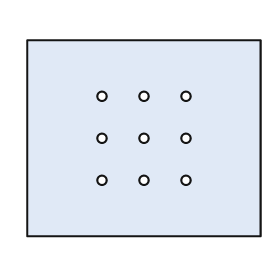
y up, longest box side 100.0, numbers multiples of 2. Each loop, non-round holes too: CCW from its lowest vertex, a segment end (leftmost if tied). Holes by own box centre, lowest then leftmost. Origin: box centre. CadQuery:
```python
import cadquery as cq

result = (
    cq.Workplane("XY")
    .moveTo(-50.0, -42.0)
    .lineTo(50.0, -42.0)
    .lineTo(50.0, 42.0)
    .lineTo(-50.0, 42.0)
    .close()
    .moveTo(-18.0, -18.0)
    .circle(2.0)
    .moveTo(0.0, -18.0)
    .circle(2.0)
    .moveTo(18.0, -18.0)
    .circle(2.0)
    .moveTo(-18.0, 0.0)
    .circle(2.0)
    .moveTo(0.0, 0.0)
    .circle(2.0)
    .moveTo(18.0, 0.0)
    .circle(2.0)
    .moveTo(-18.0, 18.0)
    .circle(2.0)
    .moveTo(0.0, 18.0)
    .circle(2.0)
    .moveTo(18.0, 18.0)
    .circle(2.0)
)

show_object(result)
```